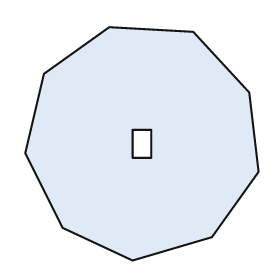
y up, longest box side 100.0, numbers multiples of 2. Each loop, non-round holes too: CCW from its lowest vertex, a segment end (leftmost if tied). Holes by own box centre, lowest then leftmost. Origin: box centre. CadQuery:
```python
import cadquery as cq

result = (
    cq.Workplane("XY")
    .moveTo(-4.0, -50.0)
    .lineTo(30.0, -40.0)
    .lineTo(50.0, -12.0)
    .lineTo(46.0, 22.0)
    .lineTo(22.0, 48.0)
    .lineTo(-14.0, 50.0)
    .lineTo(-42.0, 30.0)
    .lineTo(-50.0, -4.0)
    .lineTo(-34.0, -36.0)
    .close()
    .moveTo(-4.0, -6.0)
    .lineTo(4.0, -6.0)
    .lineTo(4.0, 6.0)
    .lineTo(-4.0, 6.0)
    .close()
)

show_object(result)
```